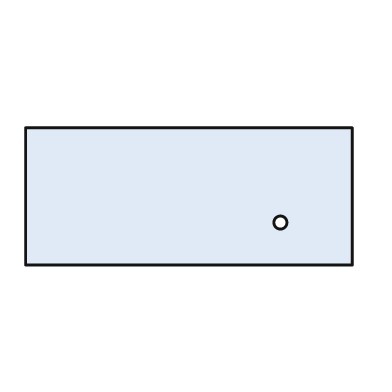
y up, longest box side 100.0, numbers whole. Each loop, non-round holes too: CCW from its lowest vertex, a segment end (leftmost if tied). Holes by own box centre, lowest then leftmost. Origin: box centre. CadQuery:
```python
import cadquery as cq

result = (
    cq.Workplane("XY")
    .moveTo(-50.0, -21.0)
    .lineTo(50.0, -21.0)
    .lineTo(50.0, 21.0)
    .lineTo(-50.0, 21.0)
    .close()
    .moveTo(28.0, -8.0)
    .circle(2.0)
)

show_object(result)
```